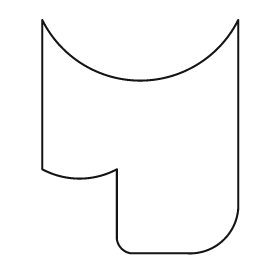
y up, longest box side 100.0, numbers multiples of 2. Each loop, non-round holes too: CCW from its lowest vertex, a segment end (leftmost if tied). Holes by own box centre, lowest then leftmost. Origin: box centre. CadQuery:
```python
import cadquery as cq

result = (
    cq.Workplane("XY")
    .moveTo(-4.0, -50.0)
    .lineTo(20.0, -50.0)
    .threePointArc((36.0, -44.0), (42.0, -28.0))
    .lineTo(42.0, 50.0)
    .threePointArc((0.0, 24.0), (-42.0, 50.0))
    .lineTo(-42.0, -14.0)
    .threePointArc((-26.0, -18.0), (-10.0, -14.0))
    .lineTo(-10.0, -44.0)
    .threePointArc((-8.0, -48.0), (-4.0, -50.0))
    .close()
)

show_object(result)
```